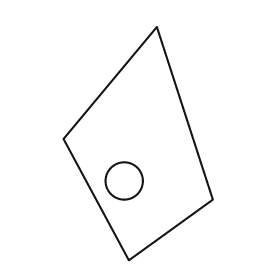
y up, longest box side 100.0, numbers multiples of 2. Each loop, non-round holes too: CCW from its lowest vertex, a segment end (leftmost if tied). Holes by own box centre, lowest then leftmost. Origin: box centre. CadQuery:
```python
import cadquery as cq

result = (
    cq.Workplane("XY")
    .moveTo(-4.0, -50.0)
    .lineTo(32.0, -24.0)
    .lineTo(8.0, 50.0)
    .lineTo(-32.0, 2.0)
    .close()
    .moveTo(-6.0, -16.0)
    .circle(8.0)
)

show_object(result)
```